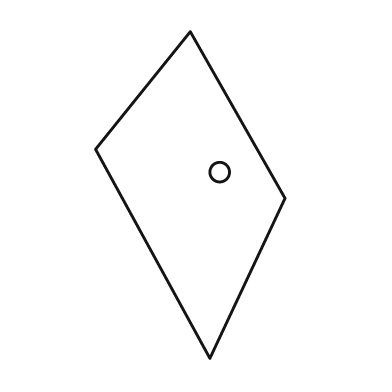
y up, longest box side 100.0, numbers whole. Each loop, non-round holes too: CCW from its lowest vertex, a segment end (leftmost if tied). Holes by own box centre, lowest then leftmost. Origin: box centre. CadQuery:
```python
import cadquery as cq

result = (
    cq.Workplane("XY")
    .moveTo(6.0, -50.0)
    .lineTo(29.0, -1.0)
    .lineTo(0.0, 50.0)
    .lineTo(-29.0, 14.0)
    .close()
    .moveTo(9.0, 7.0)
    .circle(3.0)
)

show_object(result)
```